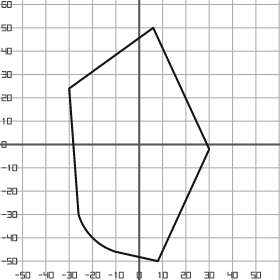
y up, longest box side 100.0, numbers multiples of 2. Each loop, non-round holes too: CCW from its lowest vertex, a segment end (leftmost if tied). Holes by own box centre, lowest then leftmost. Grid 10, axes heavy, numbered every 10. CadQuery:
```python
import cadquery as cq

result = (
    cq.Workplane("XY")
    .moveTo(8.0, -50.0)
    .lineTo(30.0, -2.0)
    .lineTo(6.0, 50.0)
    .lineTo(-30.0, 24.0)
    .lineTo(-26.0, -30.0)
    .threePointArc((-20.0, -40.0), (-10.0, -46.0))
    .close()
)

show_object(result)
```